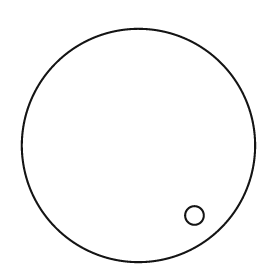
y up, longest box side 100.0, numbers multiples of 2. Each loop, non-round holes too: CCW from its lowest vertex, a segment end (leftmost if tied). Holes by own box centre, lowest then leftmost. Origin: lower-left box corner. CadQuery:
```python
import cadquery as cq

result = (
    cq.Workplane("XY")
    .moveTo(50.0, 50.0)
    .circle(50.0)
    .moveTo(74.0, 20.0)
    .circle(4.0)
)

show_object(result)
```